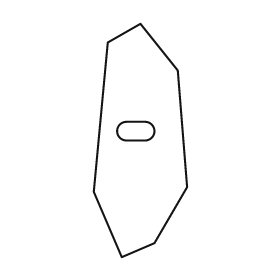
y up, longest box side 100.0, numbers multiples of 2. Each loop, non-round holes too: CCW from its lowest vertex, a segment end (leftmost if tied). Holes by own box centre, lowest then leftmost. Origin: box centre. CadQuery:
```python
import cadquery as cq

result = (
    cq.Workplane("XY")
    .moveTo(-8.0, -50.0)
    .lineTo(6.0, -44.0)
    .lineTo(20.0, -20.0)
    .lineTo(16.0, 30.0)
    .lineTo(0.0, 50.0)
    .lineTo(-14.0, 42.0)
    .lineTo(-20.0, -22.0)
    .close()
    .moveTo(-6.0, 0.0)
    .lineTo(2.0, 0.0)
    .threePointArc((6.0, 4.0), (2.0, 8.0))
    .lineTo(-6.0, 8.0)
    .threePointArc((-10.0, 4.0), (-6.0, 0.0))
    .close()
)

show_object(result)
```